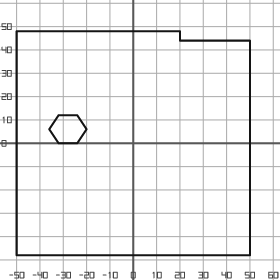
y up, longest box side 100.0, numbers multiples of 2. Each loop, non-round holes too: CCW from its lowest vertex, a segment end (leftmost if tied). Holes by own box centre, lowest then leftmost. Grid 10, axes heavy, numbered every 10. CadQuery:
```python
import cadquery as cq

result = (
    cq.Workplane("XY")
    .moveTo(-50.0, -48.0)
    .lineTo(50.0, -48.0)
    .lineTo(50.0, 44.0)
    .lineTo(20.0, 44.0)
    .lineTo(20.0, 48.0)
    .lineTo(-50.0, 48.0)
    .close()
    .moveTo(-32.0, 0.0)
    .lineTo(-24.0, 0.0)
    .lineTo(-20.0, 6.0)
    .lineTo(-24.0, 12.0)
    .lineTo(-32.0, 12.0)
    .lineTo(-36.0, 6.0)
    .close()
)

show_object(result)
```